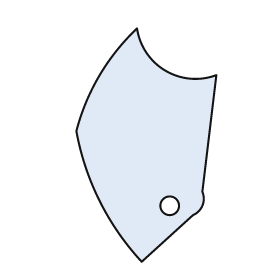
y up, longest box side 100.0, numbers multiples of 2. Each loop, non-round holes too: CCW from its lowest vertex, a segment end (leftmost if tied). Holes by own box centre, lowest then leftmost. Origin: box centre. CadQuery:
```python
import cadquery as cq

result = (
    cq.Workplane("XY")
    .moveTo(-2.0, -50.0)
    .lineTo(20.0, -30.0)
    .threePointArc((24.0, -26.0), (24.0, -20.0))
    .lineTo(30.0, 30.0)
    .threePointArc((8.0, 32.0), (-4.0, 50.0))
    .threePointArc((-20.0, 30.0), (-30.0, 6.0))
    .threePointArc((-20.0, -24.0), (-2.0, -50.0))
    .close()
    .moveTo(10.0, -26.0)
    .circle(4.0)
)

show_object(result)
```